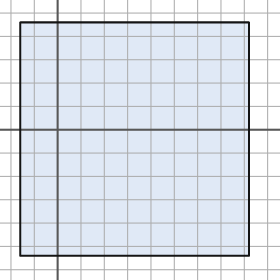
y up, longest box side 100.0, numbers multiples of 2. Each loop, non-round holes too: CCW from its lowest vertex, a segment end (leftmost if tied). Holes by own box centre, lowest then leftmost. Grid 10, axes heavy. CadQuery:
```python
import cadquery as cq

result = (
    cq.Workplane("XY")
    .moveTo(-16.0, -54.0)
    .lineTo(82.0, -54.0)
    .lineTo(82.0, 46.0)
    .lineTo(-16.0, 46.0)
    .close()
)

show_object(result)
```